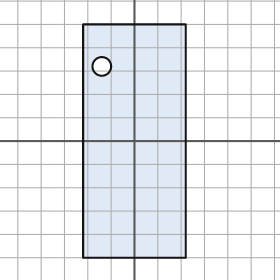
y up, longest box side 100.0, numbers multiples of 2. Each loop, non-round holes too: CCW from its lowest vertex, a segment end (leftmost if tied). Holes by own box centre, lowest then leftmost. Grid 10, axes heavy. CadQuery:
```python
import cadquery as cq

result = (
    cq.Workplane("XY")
    .moveTo(-22.0, -50.0)
    .lineTo(22.0, -50.0)
    .lineTo(22.0, 50.0)
    .lineTo(-22.0, 50.0)
    .close()
    .moveTo(-14.0, 32.0)
    .circle(4.0)
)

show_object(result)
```